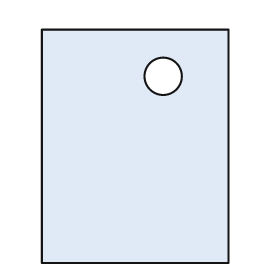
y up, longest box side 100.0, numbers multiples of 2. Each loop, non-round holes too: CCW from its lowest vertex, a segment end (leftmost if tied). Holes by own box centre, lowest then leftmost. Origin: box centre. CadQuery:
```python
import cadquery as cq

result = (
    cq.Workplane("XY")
    .moveTo(-40.0, -50.0)
    .lineTo(40.0, -50.0)
    .lineTo(40.0, 50.0)
    .lineTo(-40.0, 50.0)
    .close()
    .moveTo(12.0, 30.0)
    .circle(8.0)
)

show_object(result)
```